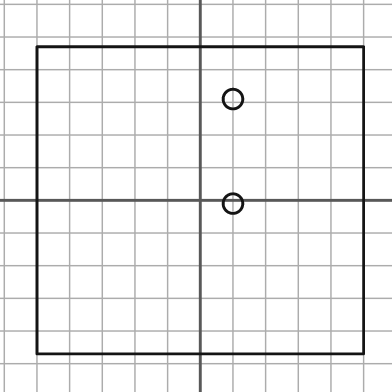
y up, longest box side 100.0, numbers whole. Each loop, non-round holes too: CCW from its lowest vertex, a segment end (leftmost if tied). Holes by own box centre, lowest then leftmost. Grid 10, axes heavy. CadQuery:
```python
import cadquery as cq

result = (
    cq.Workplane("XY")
    .moveTo(-50.0, -47.0)
    .lineTo(50.0, -47.0)
    .lineTo(50.0, 47.0)
    .lineTo(-50.0, 47.0)
    .close()
    .moveTo(10.0, -1.0)
    .circle(3.0)
    .moveTo(10.0, 31.0)
    .circle(3.0)
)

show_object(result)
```